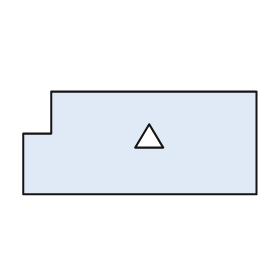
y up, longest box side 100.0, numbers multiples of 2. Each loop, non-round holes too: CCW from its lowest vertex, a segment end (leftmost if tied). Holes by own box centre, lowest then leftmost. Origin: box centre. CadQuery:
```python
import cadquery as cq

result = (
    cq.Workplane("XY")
    .moveTo(-50.0, -22.0)
    .lineTo(50.0, -22.0)
    .lineTo(50.0, 22.0)
    .lineTo(-38.0, 22.0)
    .lineTo(-38.0, 4.0)
    .lineTo(-50.0, 4.0)
    .close()
    .moveTo(-2.0, -2.0)
    .lineTo(10.0, -2.0)
    .lineTo(4.0, 8.0)
    .close()
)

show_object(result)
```